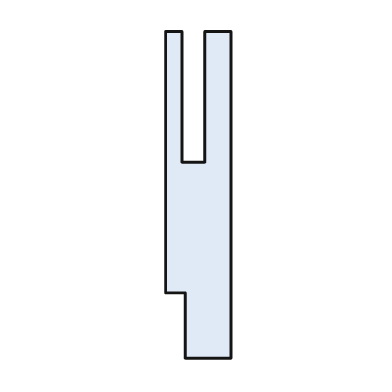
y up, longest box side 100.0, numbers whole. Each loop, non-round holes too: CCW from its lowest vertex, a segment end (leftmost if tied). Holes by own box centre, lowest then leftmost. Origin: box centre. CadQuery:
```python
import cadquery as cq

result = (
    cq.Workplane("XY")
    .moveTo(-4.0, -50.0)
    .lineTo(10.0, -50.0)
    .lineTo(10.0, 50.0)
    .lineTo(2.0, 50.0)
    .lineTo(2.0, 10.0)
    .lineTo(-5.0, 10.0)
    .lineTo(-5.0, 50.0)
    .lineTo(-10.0, 50.0)
    .lineTo(-10.0, -30.0)
    .lineTo(-4.0, -30.0)
    .close()
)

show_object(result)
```